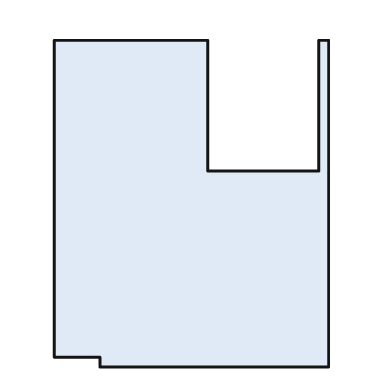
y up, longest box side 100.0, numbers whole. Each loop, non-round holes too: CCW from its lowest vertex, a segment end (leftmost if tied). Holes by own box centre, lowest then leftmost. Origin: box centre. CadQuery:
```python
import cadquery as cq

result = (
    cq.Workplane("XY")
    .moveTo(-28.0, -50.0)
    .lineTo(42.0, -50.0)
    .lineTo(42.0, 50.0)
    .lineTo(39.0, 50.0)
    .lineTo(39.0, 10.0)
    .lineTo(5.0, 10.0)
    .lineTo(5.0, 50.0)
    .lineTo(-42.0, 50.0)
    .lineTo(-42.0, -47.0)
    .lineTo(-28.0, -47.0)
    .close()
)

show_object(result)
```